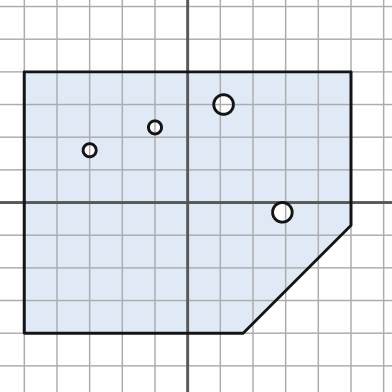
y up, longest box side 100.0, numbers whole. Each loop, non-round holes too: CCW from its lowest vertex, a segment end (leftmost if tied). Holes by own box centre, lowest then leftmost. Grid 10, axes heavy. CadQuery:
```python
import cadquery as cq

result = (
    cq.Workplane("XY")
    .moveTo(-50.0, -40.0)
    .lineTo(17.0, -40.0)
    .lineTo(50.0, -7.0)
    .lineTo(50.0, 40.0)
    .lineTo(-50.0, 40.0)
    .close()
    .moveTo(29.0, -3.0)
    .circle(3.0)
    .moveTo(-30.0, 16.0)
    .circle(2.0)
    .moveTo(-10.0, 23.0)
    .circle(2.0)
    .moveTo(11.0, 30.0)
    .circle(3.0)
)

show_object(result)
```